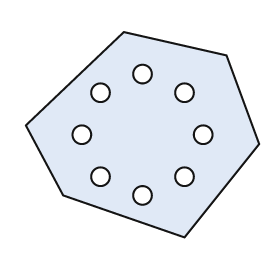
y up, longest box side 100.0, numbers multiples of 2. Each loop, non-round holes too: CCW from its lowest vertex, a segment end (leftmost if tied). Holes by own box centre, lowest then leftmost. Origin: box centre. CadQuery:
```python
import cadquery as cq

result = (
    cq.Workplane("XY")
    .moveTo(18.0, -44.0)
    .lineTo(50.0, -4.0)
    .lineTo(36.0, 34.0)
    .lineTo(-8.0, 44.0)
    .lineTo(-50.0, 4.0)
    .lineTo(-34.0, -26.0)
    .close()
    .moveTo(0.0, -26.0)
    .circle(4.0)
    .moveTo(-18.0, -18.0)
    .circle(4.0)
    .moveTo(18.0, -18.0)
    .circle(4.0)
    .moveTo(-26.0, 0.0)
    .circle(4.0)
    .moveTo(26.0, 0.0)
    .circle(4.0)
    .moveTo(-18.0, 18.0)
    .circle(4.0)
    .moveTo(18.0, 18.0)
    .circle(4.0)
    .moveTo(0.0, 26.0)
    .circle(4.0)
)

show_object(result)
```